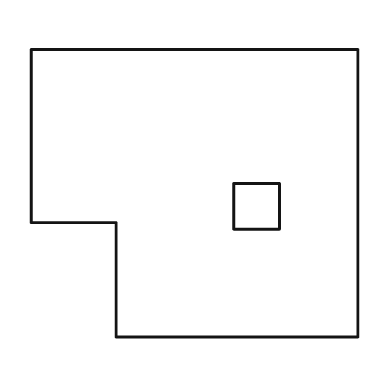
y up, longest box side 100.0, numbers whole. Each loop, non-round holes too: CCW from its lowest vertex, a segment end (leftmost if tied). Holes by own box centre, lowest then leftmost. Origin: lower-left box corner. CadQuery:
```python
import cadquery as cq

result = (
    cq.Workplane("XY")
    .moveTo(26.0, 0.0)
    .lineTo(100.0, 0.0)
    .lineTo(100.0, 88.0)
    .lineTo(0.0, 88.0)
    .lineTo(0.0, 35.0)
    .lineTo(26.0, 35.0)
    .close()
    .moveTo(62.0, 33.0)
    .lineTo(76.0, 33.0)
    .lineTo(76.0, 47.0)
    .lineTo(62.0, 47.0)
    .close()
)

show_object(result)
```